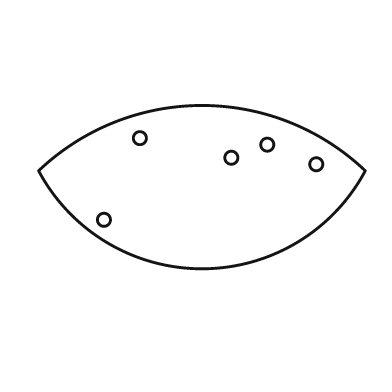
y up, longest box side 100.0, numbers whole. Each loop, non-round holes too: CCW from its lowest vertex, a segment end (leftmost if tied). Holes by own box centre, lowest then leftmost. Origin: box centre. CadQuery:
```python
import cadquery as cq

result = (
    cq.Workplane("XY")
    .moveTo(-50.0, 5.0)
    .threePointArc((0.0, -25.0), (50.0, 5.0))
    .threePointArc((0.0, 25.0), (-50.0, 5.0))
    .close()
    .moveTo(-30.0, -10.0)
    .circle(2.0)
    .moveTo(35.0, 7.0)
    .circle(2.0)
    .moveTo(9.0, 9.0)
    .circle(2.0)
    .moveTo(20.0, 13.0)
    .circle(2.0)
    .moveTo(-19.0, 15.0)
    .circle(2.0)
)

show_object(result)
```